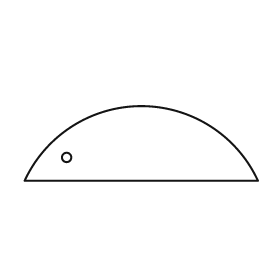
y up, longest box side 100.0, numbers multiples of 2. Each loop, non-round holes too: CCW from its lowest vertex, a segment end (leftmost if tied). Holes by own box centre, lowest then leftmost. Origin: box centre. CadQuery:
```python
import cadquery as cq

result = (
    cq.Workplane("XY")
    .moveTo(-50.0, -16.0)
    .lineTo(50.0, -16.0)
    .threePointArc((0.0, 16.0), (-50.0, -16.0))
    .close()
    .moveTo(-32.0, -6.0)
    .circle(2.0)
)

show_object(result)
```